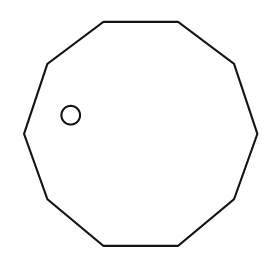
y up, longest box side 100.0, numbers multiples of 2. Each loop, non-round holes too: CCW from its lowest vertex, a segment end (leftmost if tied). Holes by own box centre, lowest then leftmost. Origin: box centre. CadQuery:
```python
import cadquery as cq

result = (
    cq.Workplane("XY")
    .moveTo(-16.0, -48.0)
    .lineTo(16.0, -48.0)
    .lineTo(40.0, -28.0)
    .lineTo(50.0, 0.0)
    .lineTo(40.0, 30.0)
    .lineTo(16.0, 48.0)
    .lineTo(-16.0, 48.0)
    .lineTo(-40.0, 30.0)
    .lineTo(-50.0, 0.0)
    .lineTo(-40.0, -28.0)
    .close()
    .moveTo(-30.0, 8.0)
    .circle(4.0)
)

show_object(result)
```